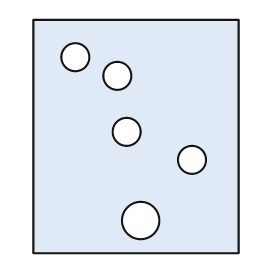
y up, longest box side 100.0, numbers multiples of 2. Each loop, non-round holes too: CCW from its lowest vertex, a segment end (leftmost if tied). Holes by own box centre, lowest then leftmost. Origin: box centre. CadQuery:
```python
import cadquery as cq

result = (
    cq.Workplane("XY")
    .moveTo(-44.0, -50.0)
    .lineTo(44.0, -50.0)
    .lineTo(44.0, 50.0)
    .lineTo(-44.0, 50.0)
    .close()
    .moveTo(2.0, -36.0)
    .circle(8.0)
    .moveTo(24.0, -10.0)
    .circle(6.0)
    .moveTo(-4.0, 2.0)
    .circle(6.0)
    .moveTo(-8.0, 26.0)
    .circle(6.0)
    .moveTo(-26.0, 34.0)
    .circle(6.0)
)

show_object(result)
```